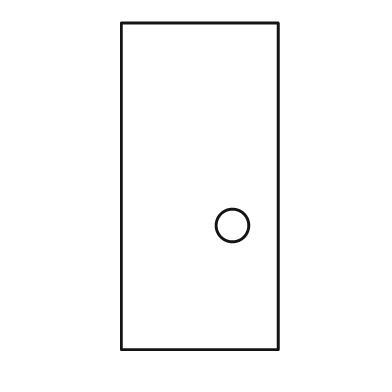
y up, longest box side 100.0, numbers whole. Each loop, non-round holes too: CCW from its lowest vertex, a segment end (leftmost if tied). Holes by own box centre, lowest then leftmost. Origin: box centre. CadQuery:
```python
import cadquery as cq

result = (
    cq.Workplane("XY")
    .moveTo(-24.0, -50.0)
    .lineTo(24.0, -50.0)
    .lineTo(24.0, 50.0)
    .lineTo(-24.0, 50.0)
    .close()
    .moveTo(10.0, -12.0)
    .circle(5.0)
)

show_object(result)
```